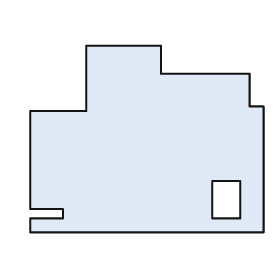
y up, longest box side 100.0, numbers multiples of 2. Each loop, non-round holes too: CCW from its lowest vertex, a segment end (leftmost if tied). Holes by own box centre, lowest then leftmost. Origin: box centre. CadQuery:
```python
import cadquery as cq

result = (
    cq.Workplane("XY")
    .moveTo(-50.0, -40.0)
    .lineTo(50.0, -40.0)
    .lineTo(50.0, 14.0)
    .lineTo(44.0, 14.0)
    .lineTo(44.0, 28.0)
    .lineTo(6.0, 28.0)
    .lineTo(6.0, 40.0)
    .lineTo(-26.0, 40.0)
    .lineTo(-26.0, 12.0)
    .lineTo(-50.0, 12.0)
    .lineTo(-50.0, -30.0)
    .lineTo(-36.0, -30.0)
    .lineTo(-36.0, -34.0)
    .lineTo(-50.0, -34.0)
    .close()
    .moveTo(28.0, -34.0)
    .lineTo(40.0, -34.0)
    .lineTo(40.0, -18.0)
    .lineTo(28.0, -18.0)
    .close()
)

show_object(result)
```